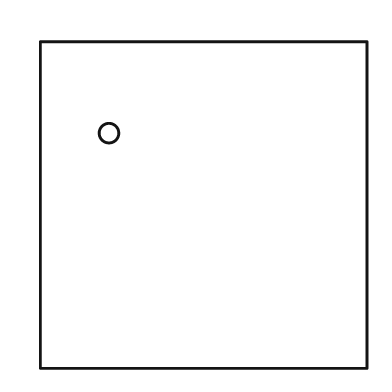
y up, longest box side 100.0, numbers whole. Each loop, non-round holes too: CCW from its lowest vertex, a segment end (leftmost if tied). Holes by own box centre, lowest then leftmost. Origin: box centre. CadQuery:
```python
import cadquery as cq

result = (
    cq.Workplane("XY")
    .moveTo(-50.0, -50.0)
    .lineTo(50.0, -50.0)
    .lineTo(50.0, 50.0)
    .lineTo(-50.0, 50.0)
    .close()
    .moveTo(-29.0, 22.0)
    .circle(3.0)
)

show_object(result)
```